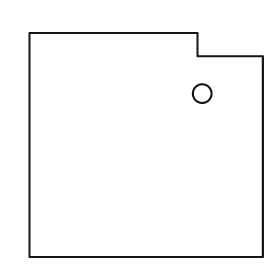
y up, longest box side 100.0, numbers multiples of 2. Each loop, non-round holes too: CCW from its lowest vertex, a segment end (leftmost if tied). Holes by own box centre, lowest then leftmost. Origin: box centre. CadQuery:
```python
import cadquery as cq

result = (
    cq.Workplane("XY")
    .moveTo(-50.0, -48.0)
    .lineTo(50.0, -48.0)
    .lineTo(50.0, 38.0)
    .lineTo(22.0, 38.0)
    .lineTo(22.0, 48.0)
    .lineTo(-50.0, 48.0)
    .close()
    .moveTo(24.0, 22.0)
    .circle(4.0)
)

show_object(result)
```